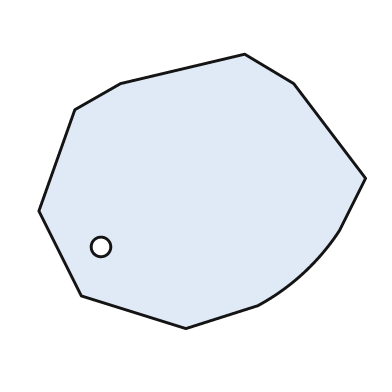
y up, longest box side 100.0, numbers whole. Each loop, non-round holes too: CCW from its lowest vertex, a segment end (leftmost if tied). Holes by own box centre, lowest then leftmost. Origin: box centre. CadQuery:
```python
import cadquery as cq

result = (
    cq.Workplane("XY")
    .moveTo(-5.0, -42.0)
    .lineTo(17.0, -35.0)
    .threePointArc((31.0, -25.0), (42.0, -12.0))
    .lineTo(50.0, 4.0)
    .lineTo(28.0, 33.0)
    .lineTo(13.0, 42.0)
    .lineTo(-25.0, 33.0)
    .lineTo(-39.0, 25.0)
    .lineTo(-50.0, -6.0)
    .lineTo(-37.0, -32.0)
    .close()
    .moveTo(-31.0, -17.0)
    .circle(3.0)
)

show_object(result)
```